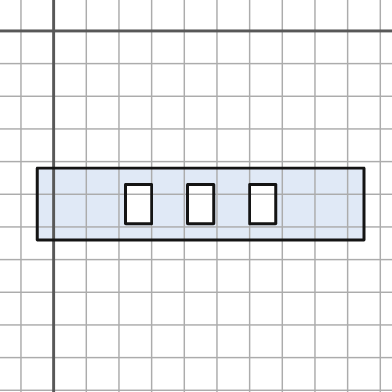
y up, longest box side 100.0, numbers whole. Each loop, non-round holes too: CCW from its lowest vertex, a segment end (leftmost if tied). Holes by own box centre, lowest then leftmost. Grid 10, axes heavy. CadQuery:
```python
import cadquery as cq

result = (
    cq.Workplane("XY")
    .moveTo(-5.0, -64.0)
    .lineTo(95.0, -64.0)
    .lineTo(95.0, -42.0)
    .lineTo(-5.0, -42.0)
    .close()
    .moveTo(22.0, -59.0)
    .lineTo(30.0, -59.0)
    .lineTo(30.0, -47.0)
    .lineTo(22.0, -47.0)
    .close()
    .moveTo(41.0, -59.0)
    .lineTo(49.0, -59.0)
    .lineTo(49.0, -47.0)
    .lineTo(41.0, -47.0)
    .close()
    .moveTo(60.0, -59.0)
    .lineTo(68.0, -59.0)
    .lineTo(68.0, -47.0)
    .lineTo(60.0, -47.0)
    .close()
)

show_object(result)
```